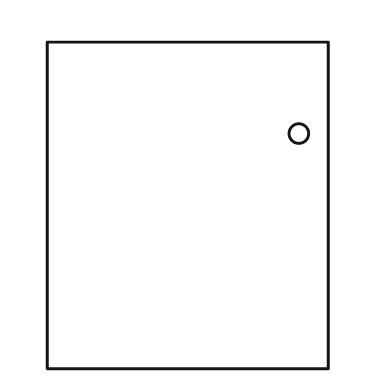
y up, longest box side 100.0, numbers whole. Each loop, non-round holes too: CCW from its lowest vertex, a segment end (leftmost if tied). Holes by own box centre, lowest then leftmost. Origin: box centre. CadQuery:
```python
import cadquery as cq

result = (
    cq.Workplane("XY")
    .moveTo(-43.0, -50.0)
    .lineTo(43.0, -50.0)
    .lineTo(43.0, 50.0)
    .lineTo(-43.0, 50.0)
    .close()
    .moveTo(34.0, 22.0)
    .circle(3.0)
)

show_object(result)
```